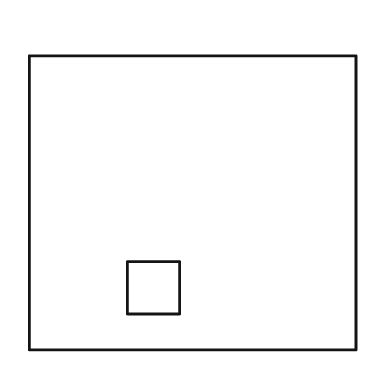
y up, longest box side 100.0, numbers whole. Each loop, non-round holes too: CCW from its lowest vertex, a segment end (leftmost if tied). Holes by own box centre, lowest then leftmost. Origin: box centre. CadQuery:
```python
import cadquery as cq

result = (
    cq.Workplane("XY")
    .moveTo(-50.0, -45.0)
    .lineTo(50.0, -45.0)
    .lineTo(50.0, 45.0)
    .lineTo(-50.0, 45.0)
    .close()
    .moveTo(-20.0, -34.0)
    .lineTo(-4.0, -34.0)
    .lineTo(-4.0, -18.0)
    .lineTo(-20.0, -18.0)
    .close()
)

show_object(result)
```